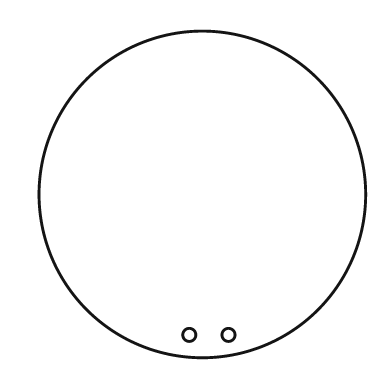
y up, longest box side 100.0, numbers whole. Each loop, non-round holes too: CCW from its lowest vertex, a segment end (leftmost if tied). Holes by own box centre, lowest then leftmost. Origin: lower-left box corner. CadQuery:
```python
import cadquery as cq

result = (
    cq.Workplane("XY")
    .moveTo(50.0, 50.0)
    .circle(50.0)
    .moveTo(46.0, 7.0)
    .circle(2.0)
    .moveTo(58.0, 7.0)
    .circle(2.0)
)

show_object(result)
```